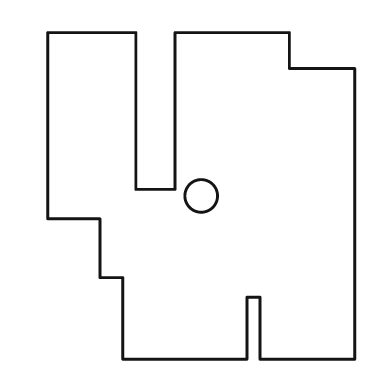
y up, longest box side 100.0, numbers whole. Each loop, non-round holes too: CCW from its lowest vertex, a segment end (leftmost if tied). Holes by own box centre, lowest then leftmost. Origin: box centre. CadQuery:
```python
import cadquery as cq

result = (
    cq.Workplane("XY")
    .moveTo(-24.0, -50.0)
    .lineTo(14.0, -50.0)
    .lineTo(14.0, -31.0)
    .lineTo(18.0, -31.0)
    .lineTo(18.0, -50.0)
    .lineTo(47.0, -50.0)
    .lineTo(47.0, 39.0)
    .lineTo(27.0, 39.0)
    .lineTo(27.0, 50.0)
    .lineTo(-8.0, 50.0)
    .lineTo(-8.0, 2.0)
    .lineTo(-20.0, 2.0)
    .lineTo(-20.0, 50.0)
    .lineTo(-47.0, 50.0)
    .lineTo(-47.0, -7.0)
    .lineTo(-31.0, -7.0)
    .lineTo(-31.0, -25.0)
    .lineTo(-24.0, -25.0)
    .close()
    .moveTo(0.0, 0.0)
    .circle(5.0)
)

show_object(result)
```